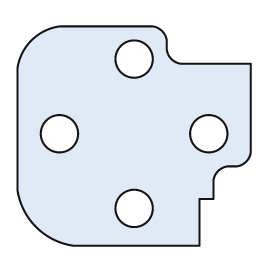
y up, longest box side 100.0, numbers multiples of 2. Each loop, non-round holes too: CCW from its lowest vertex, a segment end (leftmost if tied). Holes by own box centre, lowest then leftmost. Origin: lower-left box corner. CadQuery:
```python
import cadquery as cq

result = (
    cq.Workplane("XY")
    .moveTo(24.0, 0.0)
    .lineTo(78.0, 0.0)
    .lineTo(78.0, 20.0)
    .lineTo(84.0, 20.0)
    .lineTo(84.0, 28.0)
    .threePointArc((86.0, 32.0), (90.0, 34.0))
    .lineTo(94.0, 34.0)
    .threePointArc((98.0, 36.0), (100.0, 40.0))
    .lineTo(100.0, 78.0)
    .lineTo(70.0, 78.0)
    .threePointArc((66.0, 80.0), (64.0, 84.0))
    .lineTo(64.0, 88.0)
    .threePointArc((62.0, 92.0), (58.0, 94.0))
    .lineTo(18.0, 94.0)
    .threePointArc((6.0, 88.0), (0.0, 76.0))
    .lineTo(0.0, 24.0)
    .threePointArc((8.0, 8.0), (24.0, 0.0))
    .close()
    .moveTo(50.0, 16.0)
    .circle(8.0)
    .moveTo(18.0, 48.0)
    .circle(8.0)
    .moveTo(82.0, 48.0)
    .circle(8.0)
    .moveTo(50.0, 80.0)
    .circle(8.0)
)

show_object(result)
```